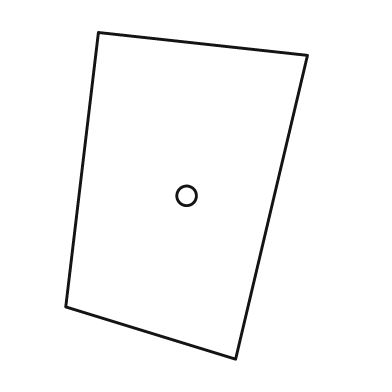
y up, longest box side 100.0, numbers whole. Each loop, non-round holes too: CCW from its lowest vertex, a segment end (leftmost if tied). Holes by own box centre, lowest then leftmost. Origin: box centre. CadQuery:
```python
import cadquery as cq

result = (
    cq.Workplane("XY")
    .moveTo(15.0, -50.0)
    .lineTo(37.0, 43.0)
    .lineTo(-27.0, 50.0)
    .lineTo(-37.0, -34.0)
    .close()
    .moveTo(0.0, 0.0)
    .circle(3.0)
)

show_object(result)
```